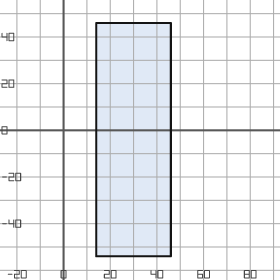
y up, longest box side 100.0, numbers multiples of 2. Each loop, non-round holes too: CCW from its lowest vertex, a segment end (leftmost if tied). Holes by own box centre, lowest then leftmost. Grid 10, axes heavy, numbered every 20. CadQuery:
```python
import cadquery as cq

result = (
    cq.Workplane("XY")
    .moveTo(14.0, -54.0)
    .lineTo(46.0, -54.0)
    .lineTo(46.0, 46.0)
    .lineTo(14.0, 46.0)
    .close()
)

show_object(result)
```